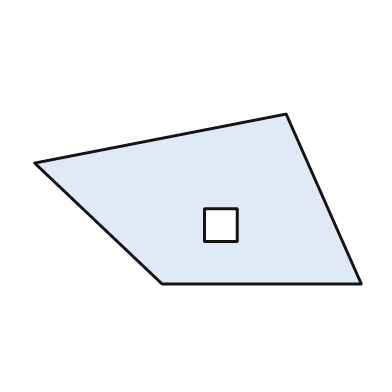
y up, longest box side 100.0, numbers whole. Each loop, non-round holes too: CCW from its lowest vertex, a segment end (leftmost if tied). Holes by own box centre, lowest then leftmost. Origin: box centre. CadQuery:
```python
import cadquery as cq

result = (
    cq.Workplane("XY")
    .moveTo(-11.0, -26.0)
    .lineTo(50.0, -26.0)
    .lineTo(27.0, 26.0)
    .lineTo(-50.0, 11.0)
    .close()
    .moveTo(2.0, -13.0)
    .lineTo(12.0, -13.0)
    .lineTo(12.0, -3.0)
    .lineTo(2.0, -3.0)
    .close()
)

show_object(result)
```